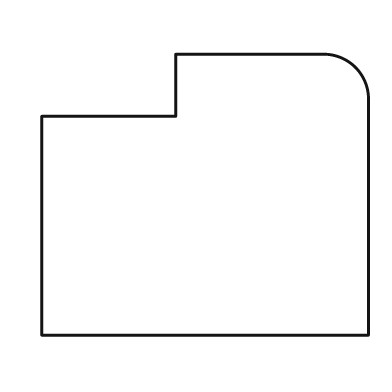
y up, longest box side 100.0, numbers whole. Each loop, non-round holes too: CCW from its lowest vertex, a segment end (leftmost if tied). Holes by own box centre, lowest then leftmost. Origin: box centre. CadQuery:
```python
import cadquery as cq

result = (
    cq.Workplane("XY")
    .moveTo(-50.0, -43.0)
    .lineTo(50.0, -43.0)
    .lineTo(50.0, 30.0)
    .threePointArc((46.0, 39.0), (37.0, 43.0))
    .lineTo(-9.0, 43.0)
    .lineTo(-9.0, 24.0)
    .lineTo(-50.0, 24.0)
    .close()
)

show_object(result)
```